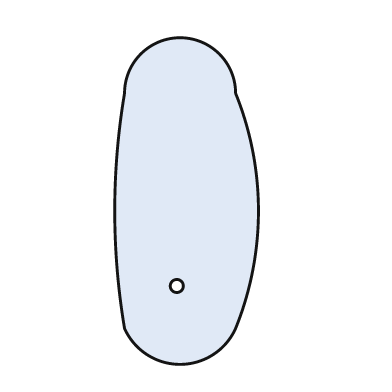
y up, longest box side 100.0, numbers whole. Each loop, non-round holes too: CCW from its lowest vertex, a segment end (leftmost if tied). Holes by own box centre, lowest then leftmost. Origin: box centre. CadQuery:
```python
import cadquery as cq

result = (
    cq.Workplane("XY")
    .moveTo(-19.0, -39.0)
    .threePointArc((-2.0, -50.0), (15.0, -39.0))
    .threePointArc((22.0, -3.0), (15.0, 33.0))
    .threePointArc((-2.0, 50.0), (-19.0, 33.0))
    .threePointArc((-22.0, -3.0), (-19.0, -39.0))
    .close()
    .moveTo(-3.0, -26.0)
    .circle(2.0)
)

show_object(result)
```